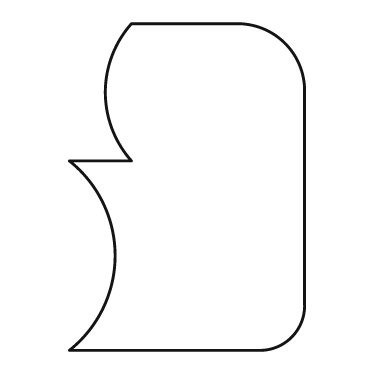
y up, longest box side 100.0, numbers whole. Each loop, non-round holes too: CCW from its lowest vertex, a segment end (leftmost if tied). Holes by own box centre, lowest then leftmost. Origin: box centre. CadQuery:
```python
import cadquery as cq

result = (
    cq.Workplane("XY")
    .moveTo(-36.0, -50.0)
    .lineTo(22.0, -50.0)
    .threePointArc((32.0, -46.0), (36.0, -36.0))
    .lineTo(36.0, 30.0)
    .threePointArc((30.0, 44.0), (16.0, 50.0))
    .lineTo(-17.0, 50.0)
    .threePointArc((-25.0, 29.0), (-17.0, 8.0))
    .lineTo(-36.0, 8.0)
    .threePointArc((-22.0, -21.0), (-36.0, -50.0))
    .close()
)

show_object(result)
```